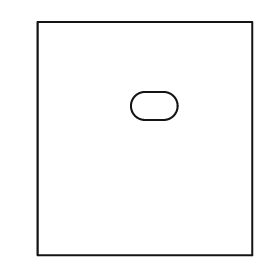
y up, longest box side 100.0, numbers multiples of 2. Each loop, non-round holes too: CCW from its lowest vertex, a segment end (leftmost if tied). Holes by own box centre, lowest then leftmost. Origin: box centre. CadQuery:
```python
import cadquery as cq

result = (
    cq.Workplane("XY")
    .moveTo(-46.0, -50.0)
    .lineTo(46.0, -50.0)
    .lineTo(46.0, 50.0)
    .lineTo(-46.0, 50.0)
    .close()
    .moveTo(0.0, 8.0)
    .lineTo(8.0, 8.0)
    .threePointArc((14.0, 14.0), (8.0, 20.0))
    .lineTo(0.0, 20.0)
    .threePointArc((-6.0, 14.0), (0.0, 8.0))
    .close()
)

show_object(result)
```